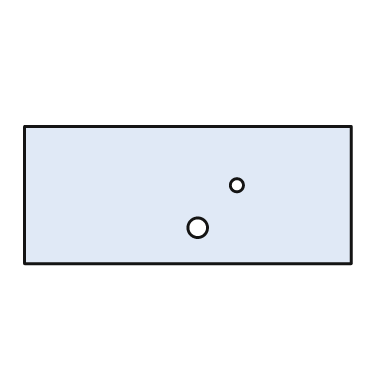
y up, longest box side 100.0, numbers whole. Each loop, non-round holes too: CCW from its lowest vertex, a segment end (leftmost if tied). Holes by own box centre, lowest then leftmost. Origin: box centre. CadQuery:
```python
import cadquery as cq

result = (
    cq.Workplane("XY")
    .moveTo(-50.0, -21.0)
    .lineTo(50.0, -21.0)
    .lineTo(50.0, 21.0)
    .lineTo(-50.0, 21.0)
    .close()
    .moveTo(3.0, -10.0)
    .circle(3.0)
    .moveTo(15.0, 3.0)
    .circle(2.0)
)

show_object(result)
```